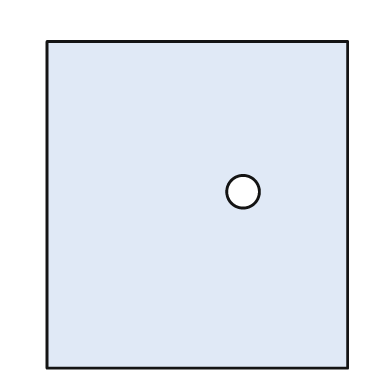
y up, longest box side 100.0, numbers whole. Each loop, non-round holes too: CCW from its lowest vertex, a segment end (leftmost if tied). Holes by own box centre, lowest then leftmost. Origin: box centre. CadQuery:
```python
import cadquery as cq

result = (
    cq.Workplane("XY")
    .moveTo(-46.0, -50.0)
    .lineTo(46.0, -50.0)
    .lineTo(46.0, 50.0)
    .lineTo(-46.0, 50.0)
    .close()
    .moveTo(14.0, 4.0)
    .circle(5.0)
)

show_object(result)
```